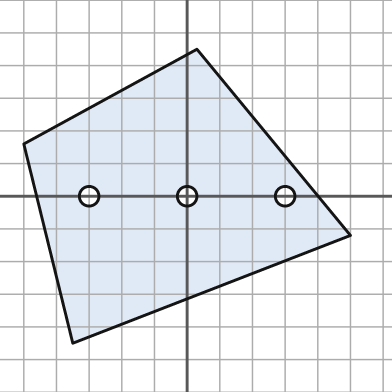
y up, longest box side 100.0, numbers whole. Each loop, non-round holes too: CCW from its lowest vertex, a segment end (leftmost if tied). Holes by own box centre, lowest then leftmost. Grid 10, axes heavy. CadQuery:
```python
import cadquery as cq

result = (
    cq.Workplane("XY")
    .moveTo(-35.0, -45.0)
    .lineTo(50.0, -12.0)
    .lineTo(3.0, 45.0)
    .lineTo(-50.0, 16.0)
    .close()
    .moveTo(-30.0, 0.0)
    .circle(3.0)
    .moveTo(0.0, 0.0)
    .circle(3.0)
    .moveTo(30.0, 0.0)
    .circle(3.0)
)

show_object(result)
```